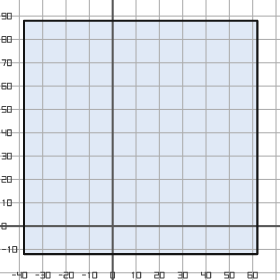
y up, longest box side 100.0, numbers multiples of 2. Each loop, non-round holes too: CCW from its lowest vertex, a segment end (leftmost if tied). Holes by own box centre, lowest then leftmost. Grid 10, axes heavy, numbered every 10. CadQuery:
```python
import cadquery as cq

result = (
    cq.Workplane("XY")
    .moveTo(-38.0, -12.0)
    .lineTo(62.0, -12.0)
    .lineTo(62.0, 88.0)
    .lineTo(-38.0, 88.0)
    .close()
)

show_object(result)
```